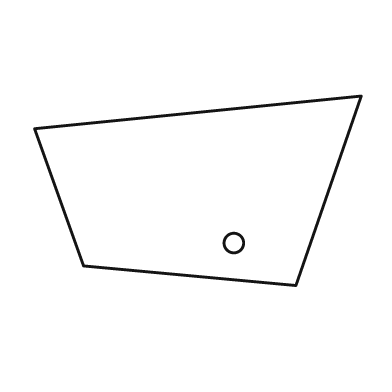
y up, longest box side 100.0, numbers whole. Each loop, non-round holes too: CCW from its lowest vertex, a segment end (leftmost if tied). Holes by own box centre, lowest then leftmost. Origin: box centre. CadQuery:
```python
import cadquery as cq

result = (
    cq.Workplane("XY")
    .moveTo(30.0, -29.0)
    .lineTo(50.0, 29.0)
    .lineTo(-50.0, 19.0)
    .lineTo(-35.0, -23.0)
    .close()
    .moveTo(11.0, -16.0)
    .circle(3.0)
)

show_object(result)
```